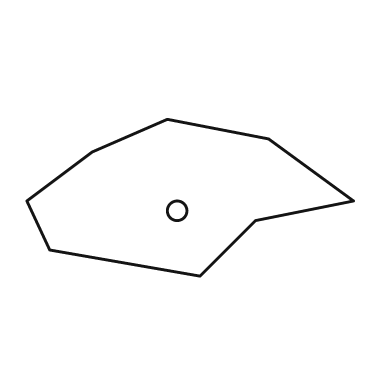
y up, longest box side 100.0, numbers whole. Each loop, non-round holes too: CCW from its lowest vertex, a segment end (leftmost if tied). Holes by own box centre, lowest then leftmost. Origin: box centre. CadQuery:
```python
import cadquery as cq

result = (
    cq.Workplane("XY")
    .moveTo(3.0, -24.0)
    .lineTo(20.0, -7.0)
    .lineTo(50.0, -1.0)
    .lineTo(24.0, 18.0)
    .lineTo(-7.0, 24.0)
    .lineTo(-30.0, 14.0)
    .lineTo(-50.0, -1.0)
    .lineTo(-43.0, -16.0)
    .close()
    .moveTo(-4.0, -4.0)
    .circle(3.0)
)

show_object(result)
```